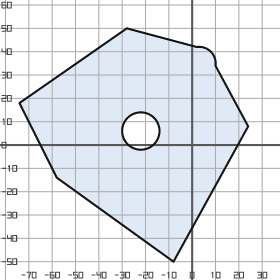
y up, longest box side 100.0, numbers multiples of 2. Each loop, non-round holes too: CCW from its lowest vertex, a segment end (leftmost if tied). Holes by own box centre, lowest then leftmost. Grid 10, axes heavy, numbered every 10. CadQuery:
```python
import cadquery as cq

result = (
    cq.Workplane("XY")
    .moveTo(-8.0, -50.0)
    .lineTo(24.0, 8.0)
    .lineTo(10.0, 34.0)
    .threePointArc((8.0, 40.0), (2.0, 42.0))
    .lineTo(-28.0, 50.0)
    .lineTo(-74.0, 18.0)
    .lineTo(-58.0, -14.0)
    .close()
    .moveTo(-22.0, 6.0)
    .circle(8.0)
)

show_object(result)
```